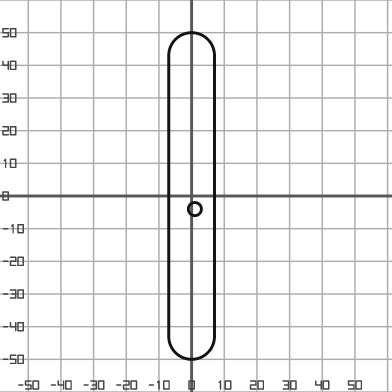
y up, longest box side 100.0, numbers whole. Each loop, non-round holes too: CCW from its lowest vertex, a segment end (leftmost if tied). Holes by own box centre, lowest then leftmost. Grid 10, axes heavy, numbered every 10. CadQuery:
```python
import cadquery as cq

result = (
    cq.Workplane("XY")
    .moveTo(-7.0, -43.0)
    .threePointArc((0.0, -50.0), (7.0, -43.0))
    .lineTo(7.0, 43.0)
    .threePointArc((0.0, 50.0), (-7.0, 43.0))
    .close()
    .moveTo(1.0, -4.0)
    .circle(2.0)
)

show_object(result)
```